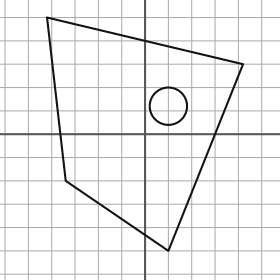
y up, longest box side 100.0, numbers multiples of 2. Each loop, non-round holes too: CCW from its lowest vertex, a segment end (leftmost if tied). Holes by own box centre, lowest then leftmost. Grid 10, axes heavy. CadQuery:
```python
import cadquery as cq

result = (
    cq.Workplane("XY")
    .moveTo(10.0, -50.0)
    .lineTo(42.0, 30.0)
    .lineTo(-42.0, 50.0)
    .lineTo(-34.0, -20.0)
    .close()
    .moveTo(10.0, 12.0)
    .circle(8.0)
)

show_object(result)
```